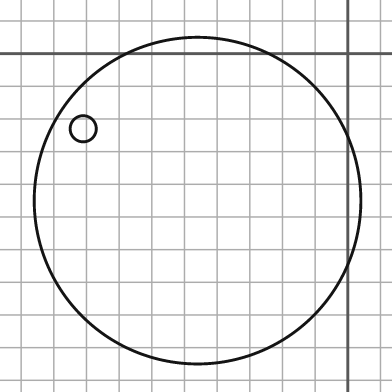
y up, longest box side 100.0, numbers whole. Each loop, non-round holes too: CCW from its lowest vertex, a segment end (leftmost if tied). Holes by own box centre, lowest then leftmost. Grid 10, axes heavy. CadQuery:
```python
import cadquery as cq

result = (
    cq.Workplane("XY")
    .moveTo(-46.0, -45.0)
    .circle(50.0)
    .moveTo(-81.0, -23.0)
    .circle(4.0)
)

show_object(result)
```